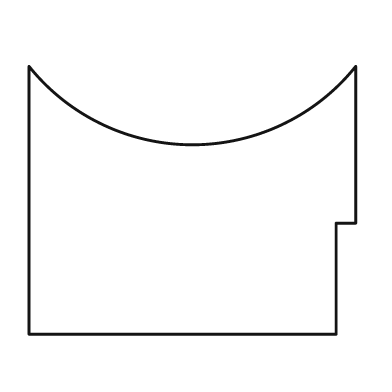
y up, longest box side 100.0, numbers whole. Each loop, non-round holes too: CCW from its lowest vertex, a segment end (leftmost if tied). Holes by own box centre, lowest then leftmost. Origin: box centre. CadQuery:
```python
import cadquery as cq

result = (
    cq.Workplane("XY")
    .moveTo(-50.0, -41.0)
    .lineTo(44.0, -41.0)
    .lineTo(44.0, -7.0)
    .lineTo(50.0, -7.0)
    .lineTo(50.0, 41.0)
    .threePointArc((0.0, 17.0), (-50.0, 41.0))
    .close()
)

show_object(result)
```